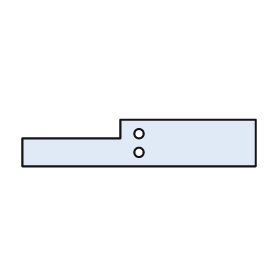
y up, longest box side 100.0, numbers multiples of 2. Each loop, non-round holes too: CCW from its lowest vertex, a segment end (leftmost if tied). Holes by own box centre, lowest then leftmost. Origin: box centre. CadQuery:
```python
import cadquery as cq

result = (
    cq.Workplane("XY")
    .moveTo(-50.0, -10.0)
    .lineTo(50.0, -10.0)
    .lineTo(50.0, 10.0)
    .lineTo(-8.0, 10.0)
    .lineTo(-8.0, 2.0)
    .lineTo(-50.0, 2.0)
    .close()
    .moveTo(0.0, -4.0)
    .circle(2.0)
    .moveTo(0.0, 4.0)
    .circle(2.0)
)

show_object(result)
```